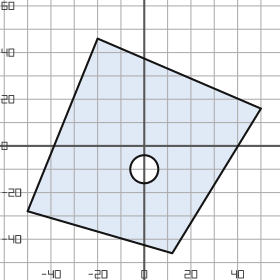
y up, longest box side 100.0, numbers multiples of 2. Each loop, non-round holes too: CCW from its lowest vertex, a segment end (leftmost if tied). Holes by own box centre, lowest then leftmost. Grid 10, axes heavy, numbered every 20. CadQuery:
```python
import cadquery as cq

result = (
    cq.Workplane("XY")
    .moveTo(12.0, -46.0)
    .lineTo(50.0, 16.0)
    .lineTo(-20.0, 46.0)
    .lineTo(-50.0, -28.0)
    .close()
    .moveTo(0.0, -10.0)
    .circle(6.0)
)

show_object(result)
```